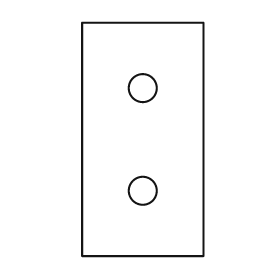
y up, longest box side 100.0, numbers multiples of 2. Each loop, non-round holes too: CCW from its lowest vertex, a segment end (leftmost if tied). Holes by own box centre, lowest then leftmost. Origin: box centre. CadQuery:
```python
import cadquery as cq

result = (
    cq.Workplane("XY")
    .moveTo(-26.0, -50.0)
    .lineTo(26.0, -50.0)
    .lineTo(26.0, 50.0)
    .lineTo(-26.0, 50.0)
    .close()
    .moveTo(0.0, -22.0)
    .circle(6.0)
    .moveTo(0.0, 22.0)
    .circle(6.0)
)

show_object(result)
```